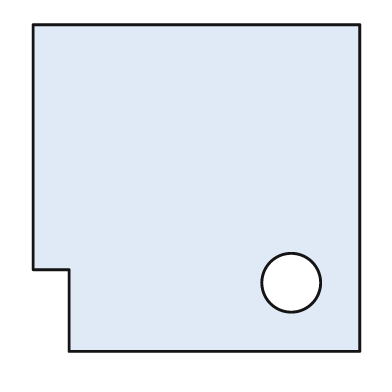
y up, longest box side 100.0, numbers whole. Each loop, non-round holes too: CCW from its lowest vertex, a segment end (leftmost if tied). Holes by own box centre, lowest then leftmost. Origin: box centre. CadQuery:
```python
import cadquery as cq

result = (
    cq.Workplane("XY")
    .moveTo(-39.0, -50.0)
    .lineTo(50.0, -50.0)
    .lineTo(50.0, 50.0)
    .lineTo(-50.0, 50.0)
    .lineTo(-50.0, -25.0)
    .lineTo(-39.0, -25.0)
    .close()
    .moveTo(29.0, -29.0)
    .circle(9.0)
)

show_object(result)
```